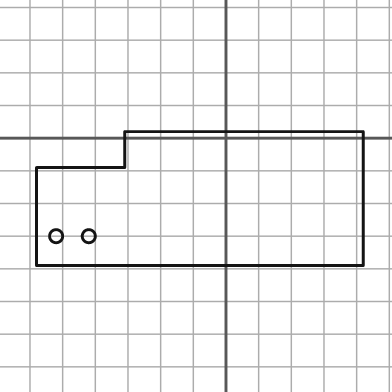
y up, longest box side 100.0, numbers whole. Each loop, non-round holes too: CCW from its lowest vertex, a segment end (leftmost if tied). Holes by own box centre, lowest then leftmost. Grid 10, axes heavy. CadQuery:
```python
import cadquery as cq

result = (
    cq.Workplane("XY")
    .moveTo(-58.0, -39.0)
    .lineTo(42.0, -39.0)
    .lineTo(42.0, 2.0)
    .lineTo(-31.0, 2.0)
    .lineTo(-31.0, -9.0)
    .lineTo(-58.0, -9.0)
    .close()
    .moveTo(-52.0, -30.0)
    .circle(2.0)
    .moveTo(-42.0, -30.0)
    .circle(2.0)
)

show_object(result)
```